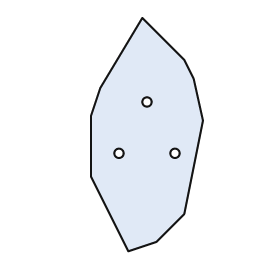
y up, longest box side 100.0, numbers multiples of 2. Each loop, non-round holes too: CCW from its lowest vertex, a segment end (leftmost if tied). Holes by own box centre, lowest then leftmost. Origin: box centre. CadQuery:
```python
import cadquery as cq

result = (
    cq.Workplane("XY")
    .moveTo(-8.0, -50.0)
    .lineTo(4.0, -46.0)
    .lineTo(16.0, -34.0)
    .lineTo(24.0, 6.0)
    .lineTo(20.0, 24.0)
    .lineTo(16.0, 32.0)
    .lineTo(-2.0, 50.0)
    .lineTo(-20.0, 20.0)
    .lineTo(-24.0, 8.0)
    .lineTo(-24.0, -18.0)
    .close()
    .moveTo(-12.0, -8.0)
    .circle(2.0)
    .moveTo(12.0, -8.0)
    .circle(2.0)
    .moveTo(0.0, 14.0)
    .circle(2.0)
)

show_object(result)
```